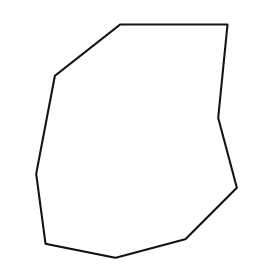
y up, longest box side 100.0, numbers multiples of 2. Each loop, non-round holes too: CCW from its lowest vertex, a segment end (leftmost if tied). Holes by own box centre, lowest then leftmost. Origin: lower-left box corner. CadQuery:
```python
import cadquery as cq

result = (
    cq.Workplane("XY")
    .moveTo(34.0, 0.0)
    .lineTo(64.0, 8.0)
    .lineTo(86.0, 30.0)
    .lineTo(78.0, 60.0)
    .lineTo(82.0, 100.0)
    .lineTo(36.0, 100.0)
    .lineTo(8.0, 78.0)
    .lineTo(0.0, 36.0)
    .lineTo(4.0, 6.0)
    .close()
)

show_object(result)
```